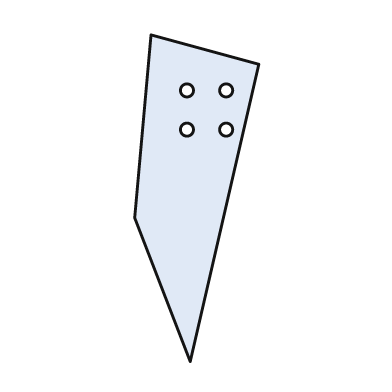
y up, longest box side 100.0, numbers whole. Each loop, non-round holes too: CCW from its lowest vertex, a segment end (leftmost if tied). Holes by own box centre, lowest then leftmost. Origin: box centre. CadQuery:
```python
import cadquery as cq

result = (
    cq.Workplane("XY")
    .moveTo(-2.0, -50.0)
    .lineTo(19.0, 41.0)
    .lineTo(-14.0, 50.0)
    .lineTo(-19.0, -6.0)
    .close()
    .moveTo(-3.0, 21.0)
    .circle(2.0)
    .moveTo(9.0, 21.0)
    .circle(2.0)
    .moveTo(-3.0, 33.0)
    .circle(2.0)
    .moveTo(9.0, 33.0)
    .circle(2.0)
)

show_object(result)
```